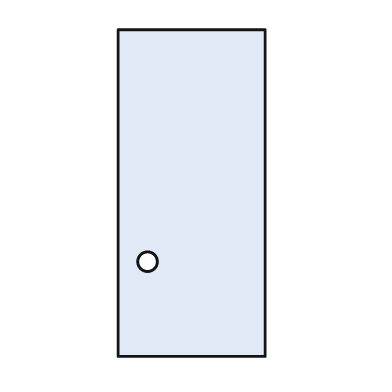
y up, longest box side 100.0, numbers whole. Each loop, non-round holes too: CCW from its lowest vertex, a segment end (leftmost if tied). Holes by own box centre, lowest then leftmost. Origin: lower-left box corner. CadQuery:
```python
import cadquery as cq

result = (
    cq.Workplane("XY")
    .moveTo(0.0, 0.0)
    .lineTo(45.0, 0.0)
    .lineTo(45.0, 100.0)
    .lineTo(0.0, 100.0)
    .close()
    .moveTo(9.0, 29.0)
    .circle(3.0)
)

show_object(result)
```